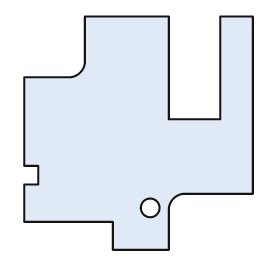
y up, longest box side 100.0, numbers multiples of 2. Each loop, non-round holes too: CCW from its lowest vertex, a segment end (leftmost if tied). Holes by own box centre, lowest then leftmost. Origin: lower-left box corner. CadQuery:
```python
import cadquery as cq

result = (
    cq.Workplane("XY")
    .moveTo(38.0, 0.0)
    .lineTo(62.0, 0.0)
    .lineTo(62.0, 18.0)
    .threePointArc((64.0, 22.0), (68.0, 24.0))
    .lineTo(98.0, 24.0)
    .lineTo(98.0, 100.0)
    .lineTo(84.0, 100.0)
    .lineTo(84.0, 56.0)
    .lineTo(62.0, 56.0)
    .lineTo(62.0, 100.0)
    .lineTo(26.0, 100.0)
    .lineTo(26.0, 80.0)
    .threePointArc((24.0, 76.0), (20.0, 74.0))
    .lineTo(0.0, 74.0)
    .lineTo(0.0, 36.0)
    .lineTo(6.0, 36.0)
    .lineTo(6.0, 28.0)
    .lineTo(0.0, 28.0)
    .lineTo(0.0, 12.0)
    .lineTo(38.0, 12.0)
    .close()
    .moveTo(54.0, 18.0)
    .circle(4.0)
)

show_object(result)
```